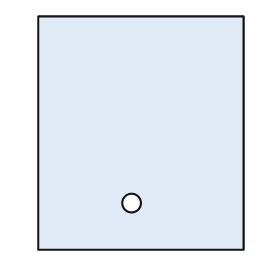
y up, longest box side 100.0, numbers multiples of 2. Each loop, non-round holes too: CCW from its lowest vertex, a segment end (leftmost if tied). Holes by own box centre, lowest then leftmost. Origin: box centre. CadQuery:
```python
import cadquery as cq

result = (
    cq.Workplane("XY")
    .moveTo(-44.0, -50.0)
    .lineTo(44.0, -50.0)
    .lineTo(44.0, 50.0)
    .lineTo(-44.0, 50.0)
    .close()
    .moveTo(-4.0, -30.0)
    .circle(4.0)
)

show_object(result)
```